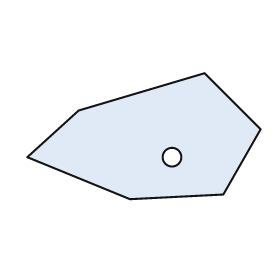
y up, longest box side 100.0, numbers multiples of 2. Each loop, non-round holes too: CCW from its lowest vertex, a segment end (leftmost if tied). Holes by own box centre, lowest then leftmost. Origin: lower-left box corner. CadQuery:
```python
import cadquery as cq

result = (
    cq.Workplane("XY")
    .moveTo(44.0, 0.0)
    .lineTo(84.0, 2.0)
    .lineTo(100.0, 30.0)
    .lineTo(76.0, 54.0)
    .lineTo(22.0, 38.0)
    .lineTo(0.0, 18.0)
    .close()
    .moveTo(62.0, 18.0)
    .circle(4.0)
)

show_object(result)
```